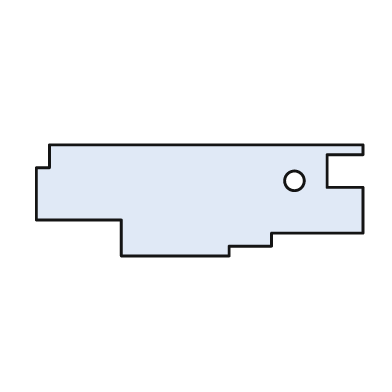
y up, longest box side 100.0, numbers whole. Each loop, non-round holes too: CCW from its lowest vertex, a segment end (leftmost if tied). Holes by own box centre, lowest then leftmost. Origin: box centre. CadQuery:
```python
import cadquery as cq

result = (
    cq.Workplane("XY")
    .moveTo(-24.0, -17.0)
    .lineTo(9.0, -17.0)
    .lineTo(9.0, -14.0)
    .lineTo(22.0, -14.0)
    .lineTo(22.0, -10.0)
    .lineTo(50.0, -10.0)
    .lineTo(50.0, 4.0)
    .lineTo(39.0, 4.0)
    .lineTo(39.0, 14.0)
    .lineTo(50.0, 14.0)
    .lineTo(50.0, 17.0)
    .lineTo(-46.0, 17.0)
    .lineTo(-46.0, 10.0)
    .lineTo(-50.0, 10.0)
    .lineTo(-50.0, -6.0)
    .lineTo(-24.0, -6.0)
    .close()
    .moveTo(29.0, 6.0)
    .circle(3.0)
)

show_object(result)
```